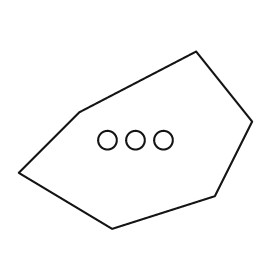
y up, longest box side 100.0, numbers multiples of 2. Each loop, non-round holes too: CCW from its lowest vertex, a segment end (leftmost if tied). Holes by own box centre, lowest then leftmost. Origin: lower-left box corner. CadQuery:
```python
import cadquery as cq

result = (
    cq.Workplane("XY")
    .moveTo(40.0, 0.0)
    .lineTo(84.0, 14.0)
    .lineTo(100.0, 46.0)
    .lineTo(76.0, 76.0)
    .lineTo(26.0, 50.0)
    .lineTo(0.0, 24.0)
    .close()
    .moveTo(38.0, 38.0)
    .circle(4.0)
    .moveTo(50.0, 38.0)
    .circle(4.0)
    .moveTo(62.0, 38.0)
    .circle(4.0)
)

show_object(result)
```